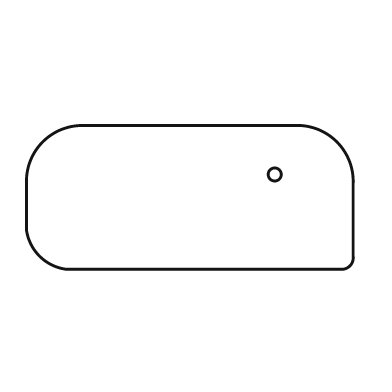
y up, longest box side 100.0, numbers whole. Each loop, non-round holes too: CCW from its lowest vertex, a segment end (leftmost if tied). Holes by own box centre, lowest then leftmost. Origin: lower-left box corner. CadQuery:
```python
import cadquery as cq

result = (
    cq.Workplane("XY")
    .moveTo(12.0, 0.0)
    .lineTo(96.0, 0.0)
    .threePointArc((99.0, 1.0), (100.0, 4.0))
    .lineTo(100.0, 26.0)
    .threePointArc((95.0, 39.0), (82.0, 44.0))
    .lineTo(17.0, 44.0)
    .threePointArc((5.0, 39.0), (0.0, 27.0))
    .lineTo(0.0, 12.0)
    .threePointArc((4.0, 4.0), (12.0, 0.0))
    .close()
    .moveTo(76.0, 29.0)
    .circle(2.0)
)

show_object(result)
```